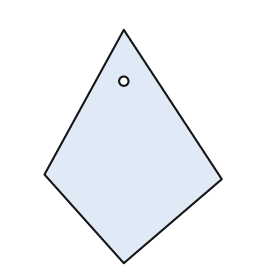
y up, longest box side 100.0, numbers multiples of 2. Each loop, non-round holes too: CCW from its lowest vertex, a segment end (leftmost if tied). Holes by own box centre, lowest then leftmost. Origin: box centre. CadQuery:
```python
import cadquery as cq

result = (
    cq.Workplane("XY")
    .moveTo(-4.0, -50.0)
    .lineTo(38.0, -14.0)
    .lineTo(-4.0, 50.0)
    .lineTo(-38.0, -12.0)
    .close()
    .moveTo(-4.0, 28.0)
    .circle(2.0)
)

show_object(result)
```